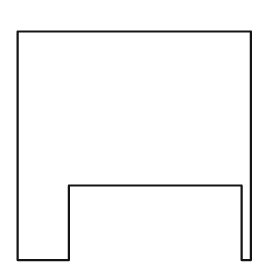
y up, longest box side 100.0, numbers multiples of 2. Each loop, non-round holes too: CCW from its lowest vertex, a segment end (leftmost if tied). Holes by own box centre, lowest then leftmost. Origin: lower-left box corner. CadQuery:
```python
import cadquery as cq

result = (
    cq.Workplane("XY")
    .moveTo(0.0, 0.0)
    .lineTo(22.0, 0.0)
    .lineTo(22.0, 32.0)
    .lineTo(96.0, 32.0)
    .lineTo(96.0, 0.0)
    .lineTo(100.0, 0.0)
    .lineTo(100.0, 98.0)
    .lineTo(0.0, 98.0)
    .close()
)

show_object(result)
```